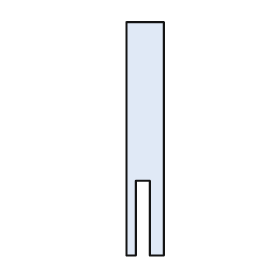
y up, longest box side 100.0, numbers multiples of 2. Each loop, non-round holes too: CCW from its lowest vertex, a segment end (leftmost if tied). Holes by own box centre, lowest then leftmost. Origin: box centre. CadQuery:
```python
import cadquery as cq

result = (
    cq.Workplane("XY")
    .moveTo(-8.0, -50.0)
    .lineTo(-4.0, -50.0)
    .lineTo(-4.0, -18.0)
    .lineTo(2.0, -18.0)
    .lineTo(2.0, -50.0)
    .lineTo(8.0, -50.0)
    .lineTo(8.0, 50.0)
    .lineTo(-8.0, 50.0)
    .close()
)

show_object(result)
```